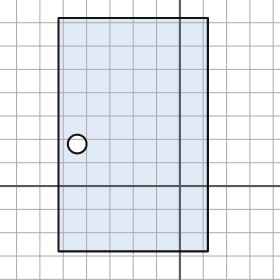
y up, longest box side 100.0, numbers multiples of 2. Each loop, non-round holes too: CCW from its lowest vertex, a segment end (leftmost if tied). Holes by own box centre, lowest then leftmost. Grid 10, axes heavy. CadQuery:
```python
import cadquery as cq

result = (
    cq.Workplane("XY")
    .moveTo(-52.0, -28.0)
    .lineTo(12.0, -28.0)
    .lineTo(12.0, 72.0)
    .lineTo(-52.0, 72.0)
    .close()
    .moveTo(-44.0, 18.0)
    .circle(4.0)
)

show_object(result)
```